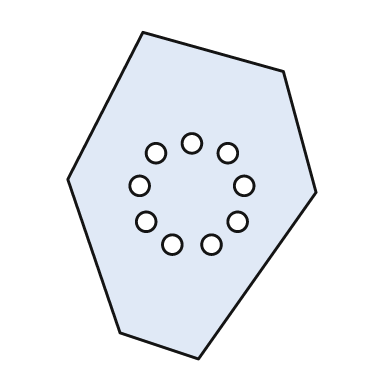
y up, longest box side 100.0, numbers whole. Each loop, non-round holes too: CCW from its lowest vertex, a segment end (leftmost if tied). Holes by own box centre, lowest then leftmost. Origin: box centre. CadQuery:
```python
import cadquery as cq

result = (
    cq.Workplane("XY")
    .moveTo(2.0, -50.0)
    .lineTo(38.0, 1.0)
    .lineTo(28.0, 38.0)
    .lineTo(-15.0, 50.0)
    .lineTo(-38.0, 5.0)
    .lineTo(-22.0, -42.0)
    .close()
    .moveTo(-6.0, -15.0)
    .circle(3.0)
    .moveTo(6.0, -15.0)
    .circle(3.0)
    .moveTo(-14.0, -8.0)
    .circle(3.0)
    .moveTo(14.0, -8.0)
    .circle(3.0)
    .moveTo(-16.0, 3.0)
    .circle(3.0)
    .moveTo(16.0, 3.0)
    .circle(3.0)
    .moveTo(-11.0, 13.0)
    .circle(3.0)
    .moveTo(11.0, 13.0)
    .circle(3.0)
    .moveTo(0.0, 16.0)
    .circle(3.0)
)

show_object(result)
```